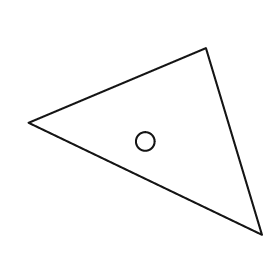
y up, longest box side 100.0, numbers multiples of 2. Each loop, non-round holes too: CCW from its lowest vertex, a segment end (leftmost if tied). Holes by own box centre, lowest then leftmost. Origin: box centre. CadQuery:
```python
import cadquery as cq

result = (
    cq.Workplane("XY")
    .moveTo(50.0, -40.0)
    .lineTo(26.0, 40.0)
    .lineTo(-50.0, 8.0)
    .close()
    .moveTo(0.0, 0.0)
    .circle(4.0)
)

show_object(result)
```